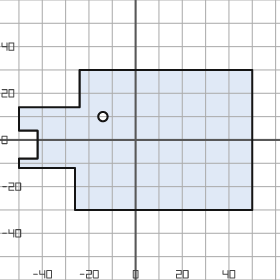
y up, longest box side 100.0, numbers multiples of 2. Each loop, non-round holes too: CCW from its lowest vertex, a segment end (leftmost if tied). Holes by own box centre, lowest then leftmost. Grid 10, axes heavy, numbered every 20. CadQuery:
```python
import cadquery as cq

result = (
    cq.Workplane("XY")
    .moveTo(-26.0, -30.0)
    .lineTo(50.0, -30.0)
    .lineTo(50.0, 30.0)
    .lineTo(-24.0, 30.0)
    .lineTo(-24.0, 14.0)
    .lineTo(-50.0, 14.0)
    .lineTo(-50.0, 4.0)
    .lineTo(-42.0, 4.0)
    .lineTo(-42.0, -8.0)
    .lineTo(-50.0, -8.0)
    .lineTo(-50.0, -12.0)
    .lineTo(-26.0, -12.0)
    .close()
    .moveTo(-14.0, 10.0)
    .circle(2.0)
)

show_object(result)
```